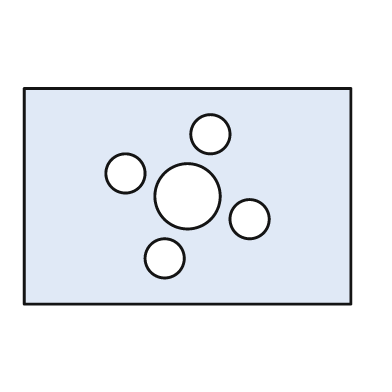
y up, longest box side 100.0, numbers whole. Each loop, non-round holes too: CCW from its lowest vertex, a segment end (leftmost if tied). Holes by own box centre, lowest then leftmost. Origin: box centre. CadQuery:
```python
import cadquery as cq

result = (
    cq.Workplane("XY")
    .moveTo(-50.0, -33.0)
    .lineTo(50.0, -33.0)
    .lineTo(50.0, 33.0)
    .lineTo(-50.0, 33.0)
    .close()
    .moveTo(-7.0, -19.0)
    .circle(6.0)
    .moveTo(19.0, -7.0)
    .circle(6.0)
    .moveTo(0.0, 0.0)
    .circle(10.0)
    .moveTo(-19.0, 7.0)
    .circle(6.0)
    .moveTo(7.0, 19.0)
    .circle(6.0)
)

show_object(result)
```